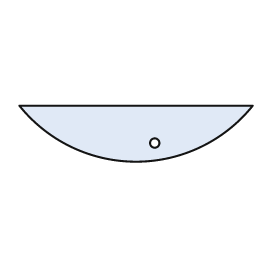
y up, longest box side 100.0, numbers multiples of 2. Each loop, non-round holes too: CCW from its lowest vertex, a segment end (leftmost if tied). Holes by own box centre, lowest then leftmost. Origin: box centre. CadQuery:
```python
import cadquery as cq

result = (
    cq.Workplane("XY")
    .moveTo(-50.0, 12.0)
    .threePointArc((0.0, -12.0), (50.0, 12.0))
    .close()
    .moveTo(8.0, -4.0)
    .circle(2.0)
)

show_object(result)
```